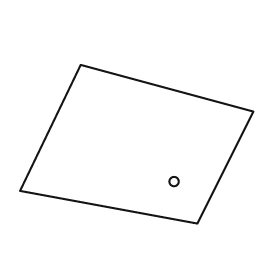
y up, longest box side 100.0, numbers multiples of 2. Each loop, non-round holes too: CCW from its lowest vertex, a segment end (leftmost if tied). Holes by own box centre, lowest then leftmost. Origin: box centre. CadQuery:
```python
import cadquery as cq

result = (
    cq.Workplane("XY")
    .moveTo(26.0, -34.0)
    .lineTo(50.0, 14.0)
    .lineTo(-24.0, 34.0)
    .lineTo(-50.0, -20.0)
    .close()
    .moveTo(16.0, -16.0)
    .circle(2.0)
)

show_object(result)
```